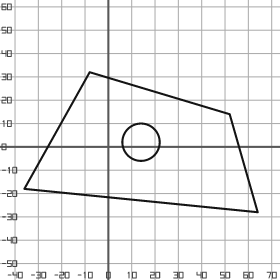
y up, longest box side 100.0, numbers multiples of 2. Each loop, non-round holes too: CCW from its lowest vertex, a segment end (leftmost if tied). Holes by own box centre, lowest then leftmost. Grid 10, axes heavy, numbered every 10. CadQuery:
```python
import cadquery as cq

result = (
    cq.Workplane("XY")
    .moveTo(64.0, -28.0)
    .lineTo(52.0, 14.0)
    .lineTo(-8.0, 32.0)
    .lineTo(-36.0, -18.0)
    .close()
    .moveTo(14.0, 2.0)
    .circle(8.0)
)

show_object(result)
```